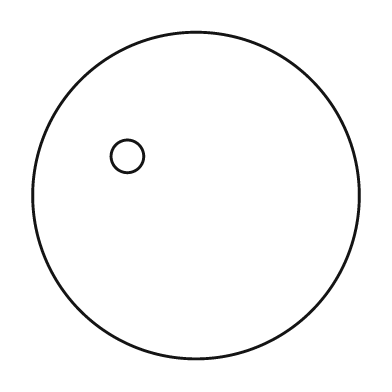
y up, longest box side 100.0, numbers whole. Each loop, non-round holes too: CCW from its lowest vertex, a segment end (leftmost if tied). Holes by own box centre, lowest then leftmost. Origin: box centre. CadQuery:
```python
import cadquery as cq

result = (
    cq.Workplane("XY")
    .moveTo(0.0, 0.0)
    .circle(50.0)
    .moveTo(-21.0, 12.0)
    .circle(5.0)
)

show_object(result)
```